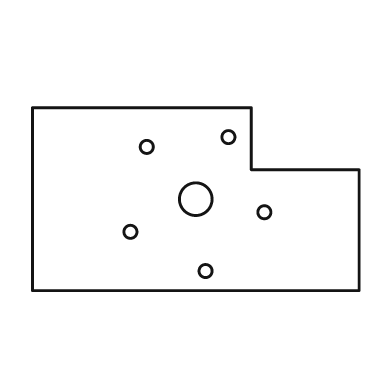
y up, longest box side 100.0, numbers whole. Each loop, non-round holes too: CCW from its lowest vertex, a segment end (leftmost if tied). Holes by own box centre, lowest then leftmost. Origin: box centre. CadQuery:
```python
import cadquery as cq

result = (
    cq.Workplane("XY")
    .moveTo(-50.0, -28.0)
    .lineTo(50.0, -28.0)
    .lineTo(50.0, 9.0)
    .lineTo(17.0, 9.0)
    .lineTo(17.0, 28.0)
    .lineTo(-50.0, 28.0)
    .close()
    .moveTo(3.0, -22.0)
    .circle(2.0)
    .moveTo(-20.0, -10.0)
    .circle(2.0)
    .moveTo(21.0, -4.0)
    .circle(2.0)
    .moveTo(0.0, 0.0)
    .circle(5.0)
    .moveTo(-15.0, 16.0)
    .circle(2.0)
    .moveTo(10.0, 19.0)
    .circle(2.0)
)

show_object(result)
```